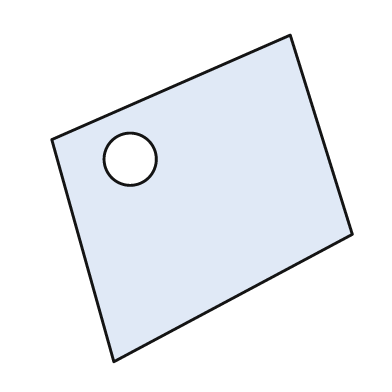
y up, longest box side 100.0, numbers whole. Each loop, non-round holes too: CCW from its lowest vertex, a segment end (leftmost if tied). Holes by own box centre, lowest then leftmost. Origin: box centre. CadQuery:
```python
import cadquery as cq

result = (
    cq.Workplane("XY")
    .moveTo(-27.0, -50.0)
    .lineTo(46.0, -11.0)
    .lineTo(27.0, 50.0)
    .lineTo(-46.0, 18.0)
    .close()
    .moveTo(-22.0, 12.0)
    .circle(8.0)
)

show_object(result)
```